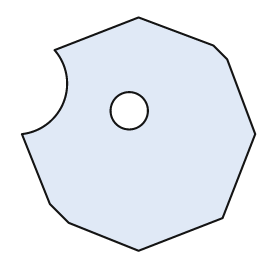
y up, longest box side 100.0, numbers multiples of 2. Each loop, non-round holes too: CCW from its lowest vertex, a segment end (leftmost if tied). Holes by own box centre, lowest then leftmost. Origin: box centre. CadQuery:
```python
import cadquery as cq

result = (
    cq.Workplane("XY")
    .moveTo(0.0, -50.0)
    .lineTo(36.0, -36.0)
    .lineTo(50.0, 0.0)
    .lineTo(38.0, 32.0)
    .lineTo(32.0, 38.0)
    .lineTo(0.0, 50.0)
    .lineTo(-36.0, 36.0)
    .threePointArc((-32.0, 14.0), (-50.0, 0.0))
    .lineTo(-38.0, -30.0)
    .lineTo(-30.0, -38.0)
    .close()
    .moveTo(-4.0, 10.0)
    .circle(8.0)
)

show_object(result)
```